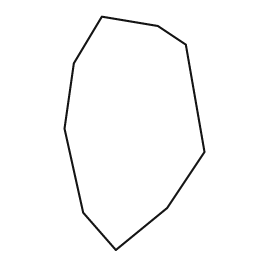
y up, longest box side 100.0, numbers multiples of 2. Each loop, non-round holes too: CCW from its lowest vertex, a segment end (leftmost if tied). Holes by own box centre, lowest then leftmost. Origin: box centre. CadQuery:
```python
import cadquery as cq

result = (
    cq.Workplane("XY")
    .moveTo(-8.0, -50.0)
    .lineTo(14.0, -32.0)
    .lineTo(30.0, -8.0)
    .lineTo(22.0, 38.0)
    .lineTo(10.0, 46.0)
    .lineTo(-14.0, 50.0)
    .lineTo(-26.0, 30.0)
    .lineTo(-30.0, 2.0)
    .lineTo(-22.0, -34.0)
    .close()
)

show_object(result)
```